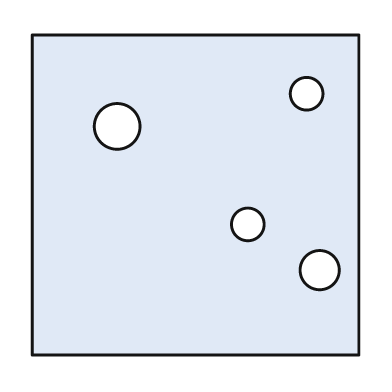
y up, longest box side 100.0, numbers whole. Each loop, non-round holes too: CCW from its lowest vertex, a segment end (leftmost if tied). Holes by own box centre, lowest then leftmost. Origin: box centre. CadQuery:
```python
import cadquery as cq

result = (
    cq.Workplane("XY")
    .moveTo(-50.0, -49.0)
    .lineTo(50.0, -49.0)
    .lineTo(50.0, 49.0)
    .lineTo(-50.0, 49.0)
    .close()
    .moveTo(38.0, -23.0)
    .circle(6.0)
    .moveTo(16.0, -9.0)
    .circle(5.0)
    .moveTo(-24.0, 21.0)
    .circle(7.0)
    .moveTo(34.0, 31.0)
    .circle(5.0)
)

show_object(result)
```